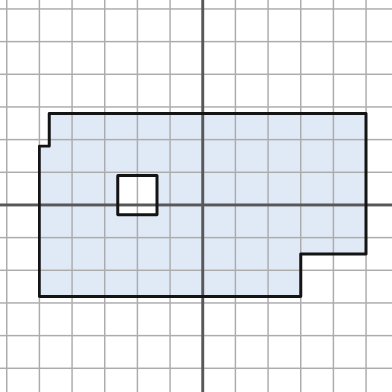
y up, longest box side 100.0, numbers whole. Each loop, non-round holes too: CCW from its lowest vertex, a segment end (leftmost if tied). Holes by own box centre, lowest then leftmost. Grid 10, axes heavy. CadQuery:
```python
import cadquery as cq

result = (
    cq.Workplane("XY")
    .moveTo(-50.0, -28.0)
    .lineTo(30.0, -28.0)
    .lineTo(30.0, -15.0)
    .lineTo(50.0, -15.0)
    .lineTo(50.0, 28.0)
    .lineTo(-47.0, 28.0)
    .lineTo(-47.0, 18.0)
    .lineTo(-50.0, 18.0)
    .close()
    .moveTo(-26.0, -3.0)
    .lineTo(-14.0, -3.0)
    .lineTo(-14.0, 9.0)
    .lineTo(-26.0, 9.0)
    .close()
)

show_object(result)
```